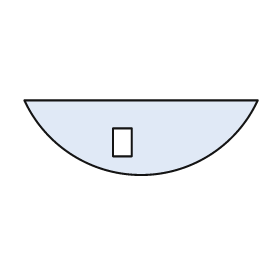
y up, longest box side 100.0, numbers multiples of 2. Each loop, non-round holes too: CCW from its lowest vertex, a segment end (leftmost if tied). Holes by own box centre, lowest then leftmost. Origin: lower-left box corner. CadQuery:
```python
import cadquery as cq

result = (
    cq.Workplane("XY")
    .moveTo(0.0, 32.0)
    .threePointArc((50.0, 0.0), (100.0, 32.0))
    .close()
    .moveTo(38.0, 8.0)
    .lineTo(46.0, 8.0)
    .lineTo(46.0, 20.0)
    .lineTo(38.0, 20.0)
    .close()
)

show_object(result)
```